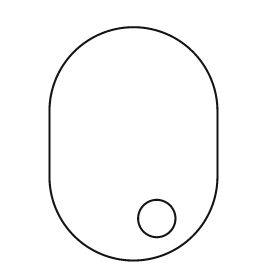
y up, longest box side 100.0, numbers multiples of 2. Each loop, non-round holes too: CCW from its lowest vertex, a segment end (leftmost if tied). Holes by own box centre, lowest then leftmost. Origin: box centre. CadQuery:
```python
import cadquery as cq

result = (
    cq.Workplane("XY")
    .moveTo(-36.0, -14.0)
    .threePointArc((0.0, -50.0), (36.0, -14.0))
    .lineTo(36.0, 14.0)
    .threePointArc((0.0, 50.0), (-36.0, 14.0))
    .close()
    .moveTo(10.0, -32.0)
    .circle(8.0)
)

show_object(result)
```